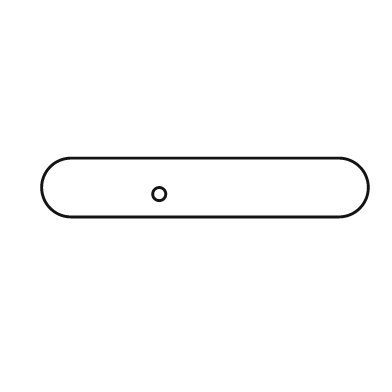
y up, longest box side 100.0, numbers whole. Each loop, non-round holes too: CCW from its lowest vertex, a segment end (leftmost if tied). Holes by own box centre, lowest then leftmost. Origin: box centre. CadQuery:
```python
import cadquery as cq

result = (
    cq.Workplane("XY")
    .moveTo(-41.0, -9.0)
    .lineTo(41.0, -9.0)
    .threePointArc((50.0, 0.0), (41.0, 9.0))
    .lineTo(-41.0, 9.0)
    .threePointArc((-50.0, 0.0), (-41.0, -9.0))
    .close()
    .moveTo(-14.0, -2.0)
    .circle(2.0)
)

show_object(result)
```